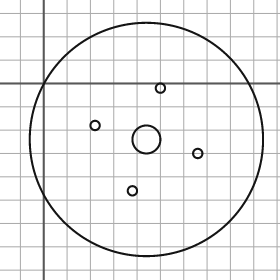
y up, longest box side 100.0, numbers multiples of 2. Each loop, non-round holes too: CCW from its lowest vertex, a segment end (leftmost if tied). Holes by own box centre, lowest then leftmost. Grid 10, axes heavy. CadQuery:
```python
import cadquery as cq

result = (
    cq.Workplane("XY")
    .moveTo(44.0, -24.0)
    .circle(50.0)
    .moveTo(38.0, -46.0)
    .circle(2.0)
    .moveTo(66.0, -30.0)
    .circle(2.0)
    .moveTo(44.0, -24.0)
    .circle(6.0)
    .moveTo(22.0, -18.0)
    .circle(2.0)
    .moveTo(50.0, -2.0)
    .circle(2.0)
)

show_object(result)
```